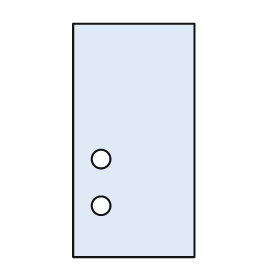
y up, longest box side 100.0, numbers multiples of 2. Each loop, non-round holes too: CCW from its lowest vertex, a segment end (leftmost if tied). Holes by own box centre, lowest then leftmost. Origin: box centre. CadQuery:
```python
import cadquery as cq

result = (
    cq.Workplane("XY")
    .moveTo(-26.0, -50.0)
    .lineTo(26.0, -50.0)
    .lineTo(26.0, 50.0)
    .lineTo(-26.0, 50.0)
    .close()
    .moveTo(-14.0, -28.0)
    .circle(4.0)
    .moveTo(-14.0, -8.0)
    .circle(4.0)
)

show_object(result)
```